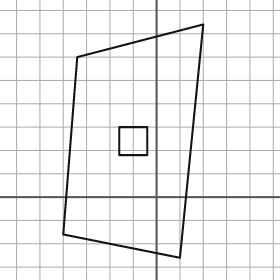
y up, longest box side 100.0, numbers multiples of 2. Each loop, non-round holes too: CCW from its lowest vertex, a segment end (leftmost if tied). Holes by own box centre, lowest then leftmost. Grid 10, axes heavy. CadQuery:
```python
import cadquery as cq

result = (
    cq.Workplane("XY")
    .moveTo(10.0, -26.0)
    .lineTo(20.0, 74.0)
    .lineTo(-34.0, 60.0)
    .lineTo(-40.0, -16.0)
    .close()
    .moveTo(-16.0, 18.0)
    .lineTo(-4.0, 18.0)
    .lineTo(-4.0, 30.0)
    .lineTo(-16.0, 30.0)
    .close()
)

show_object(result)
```